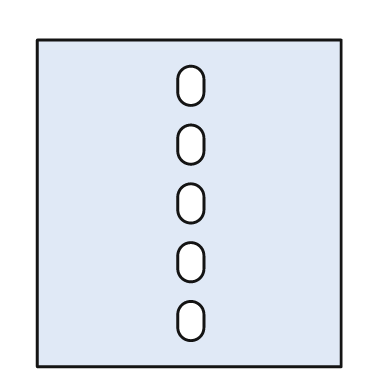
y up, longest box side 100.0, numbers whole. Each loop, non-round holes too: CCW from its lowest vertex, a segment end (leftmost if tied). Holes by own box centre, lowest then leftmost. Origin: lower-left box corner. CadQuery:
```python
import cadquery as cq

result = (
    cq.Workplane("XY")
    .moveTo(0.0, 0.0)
    .lineTo(93.0, 0.0)
    .lineTo(93.0, 100.0)
    .lineTo(0.0, 100.0)
    .close()
    .moveTo(43.0, 12.0)
    .threePointArc((47.0, 8.0), (51.0, 12.0))
    .lineTo(51.0, 16.0)
    .threePointArc((47.0, 20.0), (43.0, 16.0))
    .close()
    .moveTo(43.0, 30.0)
    .threePointArc((47.0, 26.0), (51.0, 30.0))
    .lineTo(51.0, 34.0)
    .threePointArc((47.0, 38.0), (43.0, 34.0))
    .close()
    .moveTo(43.0, 48.0)
    .threePointArc((47.0, 44.0), (51.0, 48.0))
    .lineTo(51.0, 52.0)
    .threePointArc((47.0, 56.0), (43.0, 52.0))
    .close()
    .moveTo(43.0, 66.0)
    .threePointArc((47.0, 62.0), (51.0, 66.0))
    .lineTo(51.0, 70.0)
    .threePointArc((47.0, 74.0), (43.0, 70.0))
    .close()
    .moveTo(43.0, 84.0)
    .threePointArc((47.0, 80.0), (51.0, 84.0))
    .lineTo(51.0, 88.0)
    .threePointArc((47.0, 92.0), (43.0, 88.0))
    .close()
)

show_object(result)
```